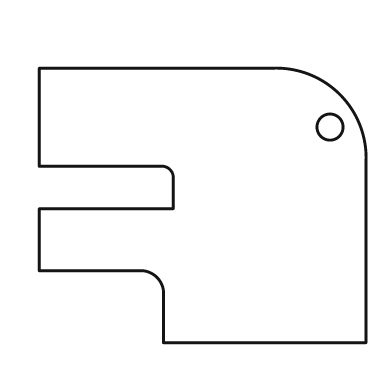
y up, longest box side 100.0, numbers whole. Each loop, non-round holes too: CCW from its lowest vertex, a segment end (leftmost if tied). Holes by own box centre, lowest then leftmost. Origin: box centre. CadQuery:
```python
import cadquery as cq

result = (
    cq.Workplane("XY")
    .moveTo(-12.0, -42.0)
    .lineTo(50.0, -42.0)
    .lineTo(50.0, 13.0)
    .threePointArc((42.0, 34.0), (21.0, 42.0))
    .lineTo(-50.0, 42.0)
    .lineTo(-50.0, 12.0)
    .lineTo(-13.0, 12.0)
    .threePointArc((-10.0, 11.0), (-9.0, 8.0))
    .lineTo(-9.0, -1.0)
    .lineTo(-50.0, -1.0)
    .lineTo(-50.0, -20.0)
    .lineTo(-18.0, -20.0)
    .threePointArc((-14.0, -22.0), (-12.0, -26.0))
    .close()
    .moveTo(39.0, 24.0)
    .circle(4.0)
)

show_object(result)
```